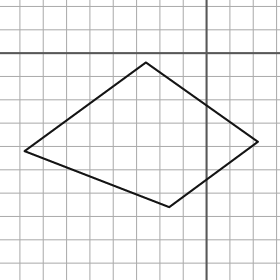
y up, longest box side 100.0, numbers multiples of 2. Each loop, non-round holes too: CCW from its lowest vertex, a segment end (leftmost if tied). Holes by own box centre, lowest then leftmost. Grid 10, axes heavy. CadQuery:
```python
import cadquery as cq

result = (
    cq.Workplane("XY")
    .moveTo(-16.0, -66.0)
    .lineTo(22.0, -38.0)
    .lineTo(-26.0, -4.0)
    .lineTo(-78.0, -42.0)
    .close()
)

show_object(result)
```